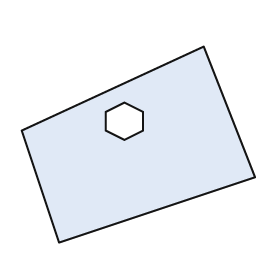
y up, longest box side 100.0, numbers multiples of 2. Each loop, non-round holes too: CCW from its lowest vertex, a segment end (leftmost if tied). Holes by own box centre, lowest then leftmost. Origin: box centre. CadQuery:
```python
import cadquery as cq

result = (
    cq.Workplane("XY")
    .moveTo(-34.0, -42.0)
    .lineTo(50.0, -14.0)
    .lineTo(28.0, 42.0)
    .lineTo(-50.0, 6.0)
    .close()
    .moveTo(-6.0, 2.0)
    .lineTo(2.0, 6.0)
    .lineTo(2.0, 14.0)
    .lineTo(-6.0, 18.0)
    .lineTo(-14.0, 14.0)
    .lineTo(-14.0, 6.0)
    .close()
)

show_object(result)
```